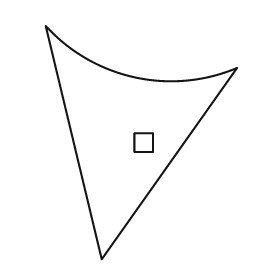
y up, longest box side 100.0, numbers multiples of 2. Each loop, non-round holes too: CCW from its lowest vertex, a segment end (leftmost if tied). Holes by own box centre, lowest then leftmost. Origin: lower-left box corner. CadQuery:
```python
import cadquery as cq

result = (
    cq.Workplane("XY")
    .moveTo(24.0, 0.0)
    .lineTo(82.0, 82.0)
    .threePointArc((38.0, 78.0), (0.0, 100.0))
    .close()
    .moveTo(38.0, 46.0)
    .lineTo(46.0, 46.0)
    .lineTo(46.0, 54.0)
    .lineTo(38.0, 54.0)
    .close()
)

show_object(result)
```